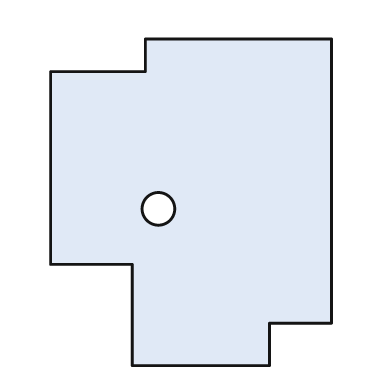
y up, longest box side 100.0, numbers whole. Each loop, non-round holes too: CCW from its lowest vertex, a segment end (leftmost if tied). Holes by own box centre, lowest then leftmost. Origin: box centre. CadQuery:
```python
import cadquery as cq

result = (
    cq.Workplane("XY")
    .moveTo(-18.0, -50.0)
    .lineTo(24.0, -50.0)
    .lineTo(24.0, -37.0)
    .lineTo(43.0, -37.0)
    .lineTo(43.0, 50.0)
    .lineTo(-14.0, 50.0)
    .lineTo(-14.0, 40.0)
    .lineTo(-43.0, 40.0)
    .lineTo(-43.0, -19.0)
    .lineTo(-18.0, -19.0)
    .close()
    .moveTo(-10.0, -2.0)
    .circle(5.0)
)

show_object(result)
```